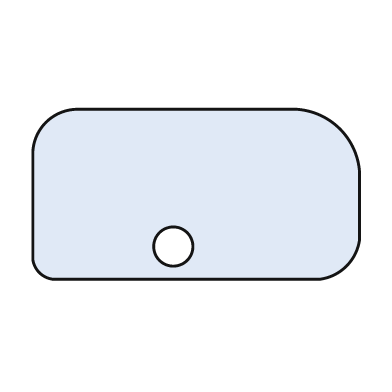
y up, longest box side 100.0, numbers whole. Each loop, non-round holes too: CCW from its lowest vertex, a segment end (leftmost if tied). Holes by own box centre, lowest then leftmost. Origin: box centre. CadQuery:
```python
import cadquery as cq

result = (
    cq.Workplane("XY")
    .moveTo(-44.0, -26.0)
    .lineTo(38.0, -26.0)
    .threePointArc((46.0, -22.0), (50.0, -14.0))
    .lineTo(50.0, 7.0)
    .threePointArc((44.0, 20.0), (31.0, 26.0))
    .lineTo(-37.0, 26.0)
    .threePointArc((-46.0, 22.0), (-50.0, 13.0))
    .lineTo(-50.0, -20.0)
    .threePointArc((-48.0, -24.0), (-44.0, -26.0))
    .close()
    .moveTo(-7.0, -16.0)
    .circle(6.0)
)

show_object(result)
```